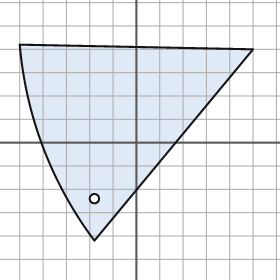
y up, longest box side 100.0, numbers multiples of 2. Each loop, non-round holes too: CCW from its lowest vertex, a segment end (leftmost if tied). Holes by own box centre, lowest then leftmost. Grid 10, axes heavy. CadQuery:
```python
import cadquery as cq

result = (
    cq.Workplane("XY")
    .moveTo(-18.0, -42.0)
    .lineTo(50.0, 40.0)
    .lineTo(-50.0, 42.0)
    .threePointArc((-40.0, -2.0), (-18.0, -42.0))
    .close()
    .moveTo(-18.0, -24.0)
    .circle(2.0)
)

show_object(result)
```